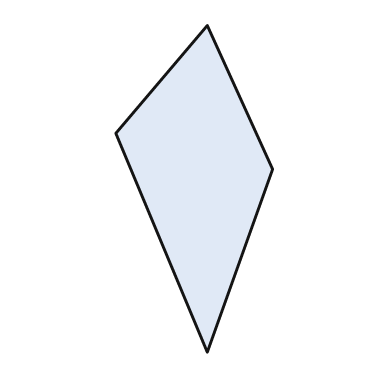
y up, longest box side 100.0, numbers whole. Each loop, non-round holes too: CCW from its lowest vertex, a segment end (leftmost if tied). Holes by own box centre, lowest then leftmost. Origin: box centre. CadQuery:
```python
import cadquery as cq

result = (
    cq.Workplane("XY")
    .moveTo(4.0, -50.0)
    .lineTo(24.0, 6.0)
    .lineTo(4.0, 50.0)
    .lineTo(-24.0, 17.0)
    .close()
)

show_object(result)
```